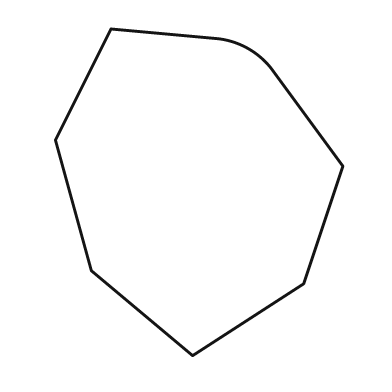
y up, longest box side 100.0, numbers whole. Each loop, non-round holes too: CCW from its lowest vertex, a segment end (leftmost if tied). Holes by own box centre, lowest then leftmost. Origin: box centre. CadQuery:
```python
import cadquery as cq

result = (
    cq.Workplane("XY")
    .moveTo(-2.0, -50.0)
    .lineTo(32.0, -28.0)
    .lineTo(44.0, 8.0)
    .lineTo(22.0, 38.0)
    .threePointArc((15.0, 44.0), (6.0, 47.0))
    .lineTo(-27.0, 50.0)
    .lineTo(-44.0, 16.0)
    .lineTo(-33.0, -24.0)
    .close()
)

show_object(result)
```